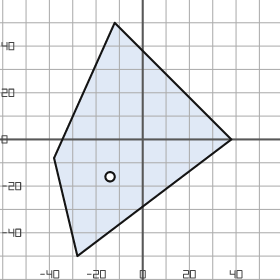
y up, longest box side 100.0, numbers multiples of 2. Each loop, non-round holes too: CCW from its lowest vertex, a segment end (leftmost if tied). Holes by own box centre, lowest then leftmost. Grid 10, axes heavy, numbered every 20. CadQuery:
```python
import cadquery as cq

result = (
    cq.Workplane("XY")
    .moveTo(-28.0, -50.0)
    .lineTo(38.0, 0.0)
    .lineTo(-12.0, 50.0)
    .lineTo(-38.0, -8.0)
    .close()
    .moveTo(-14.0, -16.0)
    .circle(2.0)
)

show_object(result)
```